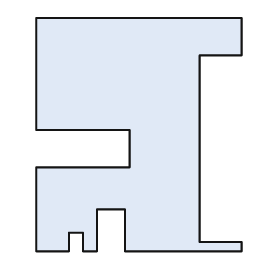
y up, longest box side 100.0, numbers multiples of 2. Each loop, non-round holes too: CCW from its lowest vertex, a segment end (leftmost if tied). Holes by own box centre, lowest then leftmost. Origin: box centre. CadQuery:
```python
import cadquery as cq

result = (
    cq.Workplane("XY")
    .moveTo(-44.0, -50.0)
    .lineTo(-30.0, -50.0)
    .lineTo(-30.0, -42.0)
    .lineTo(-24.0, -42.0)
    .lineTo(-24.0, -50.0)
    .lineTo(-18.0, -50.0)
    .lineTo(-18.0, -32.0)
    .lineTo(-6.0, -32.0)
    .lineTo(-6.0, -50.0)
    .lineTo(44.0, -50.0)
    .lineTo(44.0, -46.0)
    .lineTo(26.0, -46.0)
    .lineTo(26.0, 34.0)
    .lineTo(44.0, 34.0)
    .lineTo(44.0, 50.0)
    .lineTo(-44.0, 50.0)
    .lineTo(-44.0, 2.0)
    .lineTo(-4.0, 2.0)
    .lineTo(-4.0, -14.0)
    .lineTo(-44.0, -14.0)
    .close()
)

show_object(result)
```